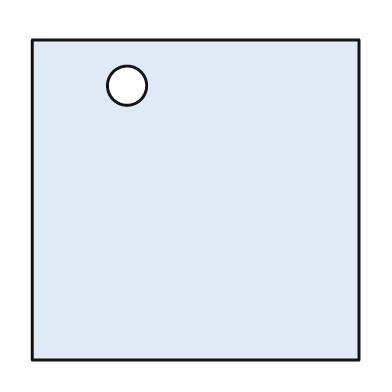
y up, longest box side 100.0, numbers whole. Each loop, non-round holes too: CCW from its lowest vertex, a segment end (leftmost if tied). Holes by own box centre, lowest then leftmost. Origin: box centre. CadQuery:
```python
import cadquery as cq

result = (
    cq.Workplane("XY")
    .moveTo(-50.0, -49.0)
    .lineTo(50.0, -49.0)
    .lineTo(50.0, 49.0)
    .lineTo(-50.0, 49.0)
    .close()
    .moveTo(-21.0, 35.0)
    .circle(6.0)
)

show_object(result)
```